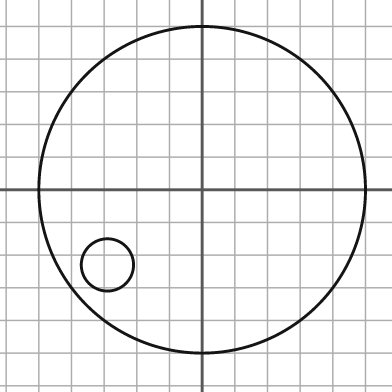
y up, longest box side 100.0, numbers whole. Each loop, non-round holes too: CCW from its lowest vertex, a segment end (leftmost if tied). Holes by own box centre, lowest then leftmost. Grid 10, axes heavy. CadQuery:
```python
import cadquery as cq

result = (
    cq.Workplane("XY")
    .moveTo(0.0, 0.0)
    .circle(50.0)
    .moveTo(-29.0, -23.0)
    .circle(8.0)
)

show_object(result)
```